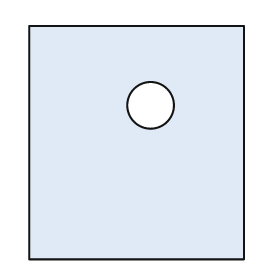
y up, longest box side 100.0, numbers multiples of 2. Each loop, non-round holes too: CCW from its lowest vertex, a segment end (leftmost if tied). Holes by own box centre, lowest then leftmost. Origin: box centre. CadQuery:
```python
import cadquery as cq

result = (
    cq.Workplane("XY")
    .moveTo(-46.0, -50.0)
    .lineTo(46.0, -50.0)
    .lineTo(46.0, 50.0)
    .lineTo(-46.0, 50.0)
    .close()
    .moveTo(6.0, 16.0)
    .circle(10.0)
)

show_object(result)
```